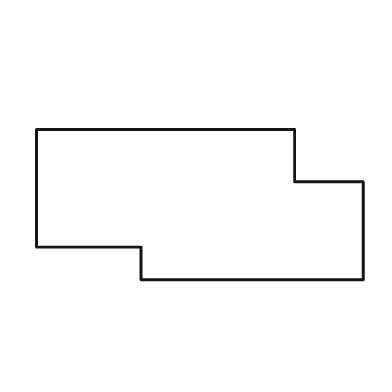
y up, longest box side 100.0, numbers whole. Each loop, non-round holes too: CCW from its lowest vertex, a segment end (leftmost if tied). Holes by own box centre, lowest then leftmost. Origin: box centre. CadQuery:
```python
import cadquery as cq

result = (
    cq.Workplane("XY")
    .moveTo(-18.0, -23.0)
    .lineTo(50.0, -23.0)
    .lineTo(50.0, 7.0)
    .lineTo(29.0, 7.0)
    .lineTo(29.0, 23.0)
    .lineTo(-50.0, 23.0)
    .lineTo(-50.0, -13.0)
    .lineTo(-18.0, -13.0)
    .close()
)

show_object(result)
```